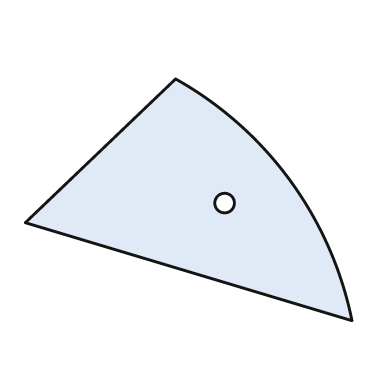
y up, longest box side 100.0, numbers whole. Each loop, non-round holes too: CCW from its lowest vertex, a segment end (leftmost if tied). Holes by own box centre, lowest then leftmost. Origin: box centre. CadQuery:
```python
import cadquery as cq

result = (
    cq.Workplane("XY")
    .moveTo(50.0, -37.0)
    .threePointArc((31.0, 6.0), (-4.0, 37.0))
    .lineTo(-50.0, -7.0)
    .close()
    .moveTo(11.0, -1.0)
    .circle(3.0)
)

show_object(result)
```